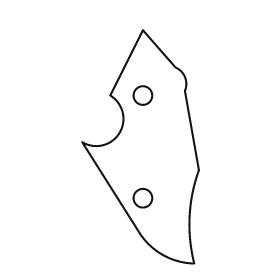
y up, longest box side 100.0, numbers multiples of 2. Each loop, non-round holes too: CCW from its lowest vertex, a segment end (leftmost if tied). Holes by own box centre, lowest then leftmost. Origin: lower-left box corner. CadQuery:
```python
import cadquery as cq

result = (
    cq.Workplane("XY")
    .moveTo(48.0, 0.0)
    .threePointArc((46.0, 20.0), (50.0, 40.0))
    .lineTo(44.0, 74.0)
    .threePointArc((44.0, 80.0), (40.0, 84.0))
    .lineTo(26.0, 100.0)
    .lineTo(12.0, 72.0)
    .threePointArc((16.0, 56.0), (0.0, 52.0))
    .lineTo(24.0, 14.0)
    .threePointArc((34.0, 4.0), (48.0, 0.0))
    .close()
    .moveTo(26.0, 28.0)
    .circle(4.0)
    .moveTo(26.0, 72.0)
    .circle(4.0)
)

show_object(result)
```